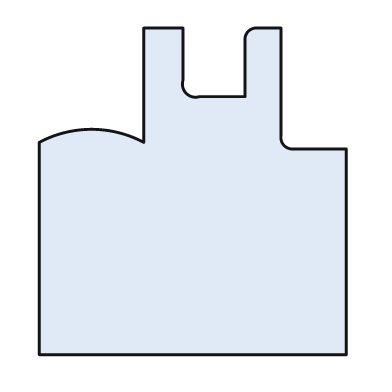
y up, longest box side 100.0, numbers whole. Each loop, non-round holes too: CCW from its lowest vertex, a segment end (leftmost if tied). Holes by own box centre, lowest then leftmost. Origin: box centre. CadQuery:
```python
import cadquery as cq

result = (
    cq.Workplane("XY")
    .moveTo(-47.0, -50.0)
    .lineTo(47.0, -50.0)
    .lineTo(47.0, 13.0)
    .lineTo(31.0, 13.0)
    .threePointArc((28.0, 14.0), (27.0, 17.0))
    .lineTo(27.0, 50.0)
    .lineTo(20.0, 50.0)
    .threePointArc((17.0, 49.0), (16.0, 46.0))
    .lineTo(16.0, 29.0)
    .lineTo(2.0, 29.0)
    .threePointArc((-2.0, 30.0), (-3.0, 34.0))
    .lineTo(-3.0, 50.0)
    .lineTo(-15.0, 50.0)
    .lineTo(-15.0, 15.0)
    .threePointArc((-31.0, 19.0), (-47.0, 15.0))
    .close()
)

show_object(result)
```